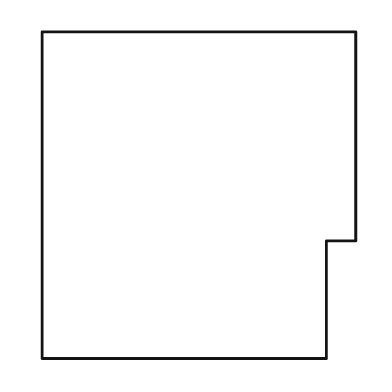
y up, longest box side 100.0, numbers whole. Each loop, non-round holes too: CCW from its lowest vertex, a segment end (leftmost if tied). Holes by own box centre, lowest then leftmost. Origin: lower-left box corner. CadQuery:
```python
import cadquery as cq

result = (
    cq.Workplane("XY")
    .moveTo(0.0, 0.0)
    .lineTo(87.0, 0.0)
    .lineTo(87.0, 36.0)
    .lineTo(96.0, 36.0)
    .lineTo(96.0, 100.0)
    .lineTo(0.0, 100.0)
    .close()
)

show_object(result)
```